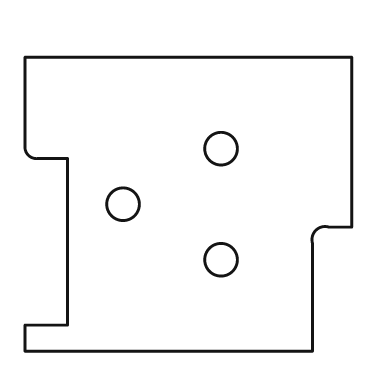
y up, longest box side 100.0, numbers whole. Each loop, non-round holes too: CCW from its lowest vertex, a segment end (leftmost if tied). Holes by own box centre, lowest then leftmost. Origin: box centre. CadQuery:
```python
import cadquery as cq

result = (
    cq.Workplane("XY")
    .moveTo(-50.0, -45.0)
    .lineTo(38.0, -45.0)
    .lineTo(38.0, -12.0)
    .threePointArc((39.0, -8.0), (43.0, -7.0))
    .lineTo(50.0, -7.0)
    .lineTo(50.0, 45.0)
    .lineTo(-50.0, 45.0)
    .lineTo(-50.0, 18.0)
    .threePointArc((-49.0, 15.0), (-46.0, 14.0))
    .lineTo(-37.0, 14.0)
    .lineTo(-37.0, -37.0)
    .lineTo(-50.0, -37.0)
    .close()
    .moveTo(10.0, -17.0)
    .circle(5.0)
    .moveTo(-20.0, 0.0)
    .circle(5.0)
    .moveTo(10.0, 17.0)
    .circle(5.0)
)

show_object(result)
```